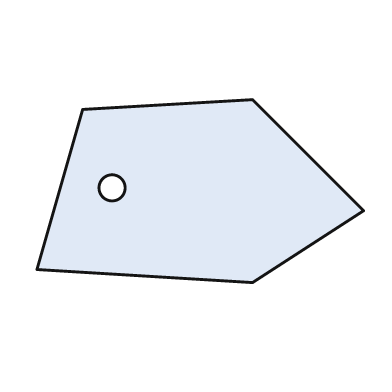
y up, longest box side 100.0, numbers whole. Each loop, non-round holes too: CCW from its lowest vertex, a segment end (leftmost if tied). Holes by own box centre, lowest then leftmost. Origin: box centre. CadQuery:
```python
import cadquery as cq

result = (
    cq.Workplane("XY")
    .moveTo(16.0, -28.0)
    .lineTo(50.0, -6.0)
    .lineTo(16.0, 28.0)
    .lineTo(-36.0, 25.0)
    .lineTo(-50.0, -24.0)
    .close()
    .moveTo(-27.0, 1.0)
    .circle(4.0)
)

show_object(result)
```